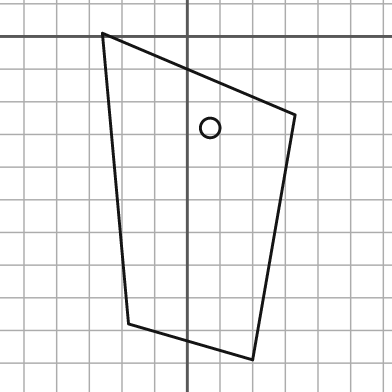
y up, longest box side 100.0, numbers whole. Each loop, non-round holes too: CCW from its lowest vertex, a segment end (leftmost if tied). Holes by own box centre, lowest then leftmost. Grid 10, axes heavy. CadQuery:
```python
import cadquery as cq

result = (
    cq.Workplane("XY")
    .moveTo(20.0, -99.0)
    .lineTo(33.0, -24.0)
    .lineTo(-26.0, 1.0)
    .lineTo(-18.0, -88.0)
    .close()
    .moveTo(7.0, -28.0)
    .circle(3.0)
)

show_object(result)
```